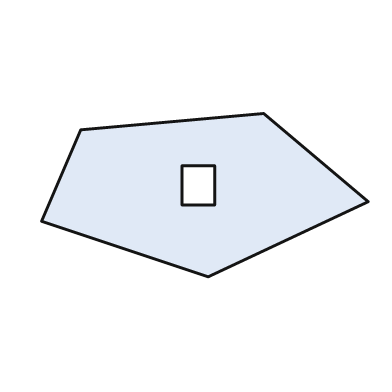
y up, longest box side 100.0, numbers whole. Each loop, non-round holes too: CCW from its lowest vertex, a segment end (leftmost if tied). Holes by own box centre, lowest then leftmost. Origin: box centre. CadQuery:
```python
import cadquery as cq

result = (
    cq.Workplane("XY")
    .moveTo(1.0, -25.0)
    .lineTo(50.0, -2.0)
    .lineTo(18.0, 25.0)
    .lineTo(-38.0, 20.0)
    .lineTo(-50.0, -8.0)
    .close()
    .moveTo(-7.0, -3.0)
    .lineTo(3.0, -3.0)
    .lineTo(3.0, 9.0)
    .lineTo(-7.0, 9.0)
    .close()
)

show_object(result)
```